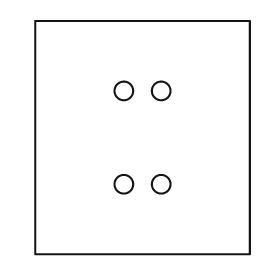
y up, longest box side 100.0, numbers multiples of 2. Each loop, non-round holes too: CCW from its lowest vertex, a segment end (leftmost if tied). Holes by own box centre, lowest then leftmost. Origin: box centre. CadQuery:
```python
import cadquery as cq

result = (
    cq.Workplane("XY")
    .moveTo(-46.0, -50.0)
    .lineTo(46.0, -50.0)
    .lineTo(46.0, 50.0)
    .lineTo(-46.0, 50.0)
    .close()
    .moveTo(-8.0, -20.0)
    .circle(4.0)
    .moveTo(8.0, -20.0)
    .circle(4.0)
    .moveTo(-8.0, 20.0)
    .circle(4.0)
    .moveTo(8.0, 20.0)
    .circle(4.0)
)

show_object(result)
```